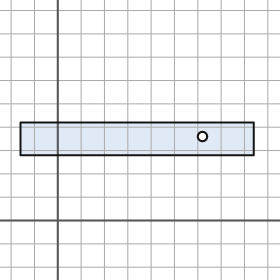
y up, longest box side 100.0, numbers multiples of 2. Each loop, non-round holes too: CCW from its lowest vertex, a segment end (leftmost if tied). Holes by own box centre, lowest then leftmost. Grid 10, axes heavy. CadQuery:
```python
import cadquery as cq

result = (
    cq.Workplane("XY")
    .moveTo(-16.0, 28.0)
    .lineTo(84.0, 28.0)
    .lineTo(84.0, 42.0)
    .lineTo(-16.0, 42.0)
    .close()
    .moveTo(62.0, 36.0)
    .circle(2.0)
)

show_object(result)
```